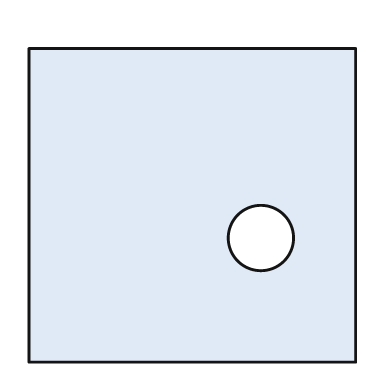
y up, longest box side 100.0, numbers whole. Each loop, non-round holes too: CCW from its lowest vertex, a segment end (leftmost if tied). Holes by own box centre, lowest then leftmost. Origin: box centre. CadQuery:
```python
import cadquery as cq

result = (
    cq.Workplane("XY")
    .moveTo(-50.0, -48.0)
    .lineTo(50.0, -48.0)
    .lineTo(50.0, 48.0)
    .lineTo(-50.0, 48.0)
    .close()
    .moveTo(21.0, -10.0)
    .circle(10.0)
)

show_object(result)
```